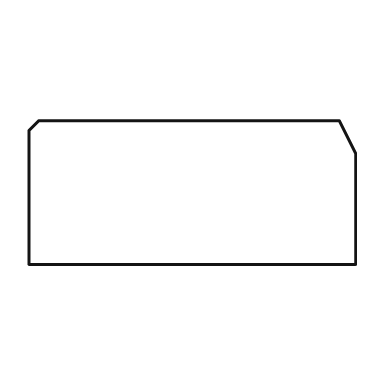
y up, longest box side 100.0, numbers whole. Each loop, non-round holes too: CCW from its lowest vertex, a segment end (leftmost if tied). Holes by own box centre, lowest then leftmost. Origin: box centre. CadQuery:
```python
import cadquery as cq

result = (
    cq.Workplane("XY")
    .moveTo(-50.0, -22.0)
    .lineTo(50.0, -22.0)
    .lineTo(50.0, 12.0)
    .lineTo(45.0, 22.0)
    .lineTo(-47.0, 22.0)
    .lineTo(-50.0, 19.0)
    .close()
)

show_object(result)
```